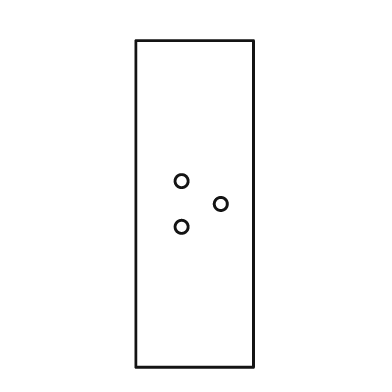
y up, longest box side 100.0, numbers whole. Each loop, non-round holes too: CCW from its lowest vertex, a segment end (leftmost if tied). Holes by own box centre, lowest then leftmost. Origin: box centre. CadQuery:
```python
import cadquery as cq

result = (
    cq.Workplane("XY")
    .moveTo(-18.0, -50.0)
    .lineTo(18.0, -50.0)
    .lineTo(18.0, 50.0)
    .lineTo(-18.0, 50.0)
    .close()
    .moveTo(-4.0, -7.0)
    .circle(2.0)
    .moveTo(8.0, 0.0)
    .circle(2.0)
    .moveTo(-4.0, 7.0)
    .circle(2.0)
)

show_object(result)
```